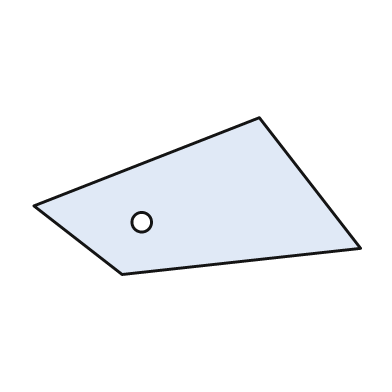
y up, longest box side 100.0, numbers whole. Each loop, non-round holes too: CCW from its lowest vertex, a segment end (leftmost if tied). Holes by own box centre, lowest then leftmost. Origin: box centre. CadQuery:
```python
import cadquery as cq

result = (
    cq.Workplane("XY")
    .moveTo(-23.0, -24.0)
    .lineTo(50.0, -16.0)
    .lineTo(19.0, 24.0)
    .lineTo(-50.0, -3.0)
    .close()
    .moveTo(-17.0, -8.0)
    .circle(3.0)
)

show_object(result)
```